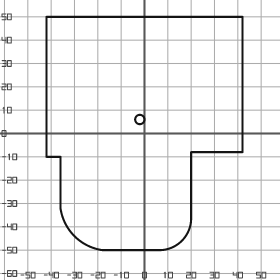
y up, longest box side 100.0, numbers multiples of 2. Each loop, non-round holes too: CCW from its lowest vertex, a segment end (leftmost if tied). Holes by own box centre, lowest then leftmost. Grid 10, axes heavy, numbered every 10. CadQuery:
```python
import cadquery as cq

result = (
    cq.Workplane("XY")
    .moveTo(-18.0, -50.0)
    .lineTo(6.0, -50.0)
    .threePointArc((16.0, -46.0), (20.0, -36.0))
    .lineTo(20.0, -8.0)
    .lineTo(42.0, -8.0)
    .lineTo(42.0, 50.0)
    .lineTo(-42.0, 50.0)
    .lineTo(-42.0, -10.0)
    .lineTo(-36.0, -10.0)
    .lineTo(-36.0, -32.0)
    .threePointArc((-30.0, -44.0), (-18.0, -50.0))
    .close()
    .moveTo(-2.0, 6.0)
    .circle(2.0)
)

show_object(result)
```